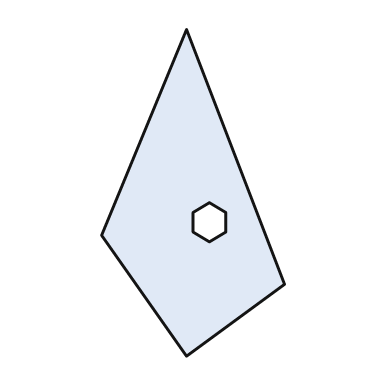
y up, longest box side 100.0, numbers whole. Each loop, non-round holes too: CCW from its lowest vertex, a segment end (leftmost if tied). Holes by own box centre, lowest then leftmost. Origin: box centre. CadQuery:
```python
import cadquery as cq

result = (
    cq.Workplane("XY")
    .moveTo(-2.0, -50.0)
    .lineTo(28.0, -28.0)
    .lineTo(-2.0, 50.0)
    .lineTo(-28.0, -13.0)
    .close()
    .moveTo(5.0, -15.0)
    .lineTo(10.0, -12.0)
    .lineTo(10.0, -6.0)
    .lineTo(5.0, -3.0)
    .lineTo(0.0, -6.0)
    .lineTo(0.0, -12.0)
    .close()
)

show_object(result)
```